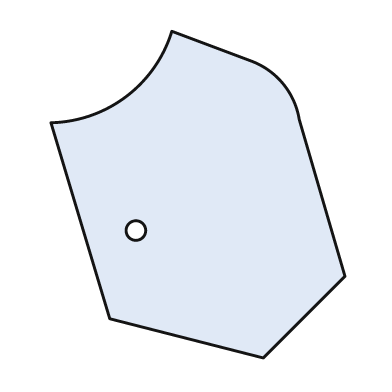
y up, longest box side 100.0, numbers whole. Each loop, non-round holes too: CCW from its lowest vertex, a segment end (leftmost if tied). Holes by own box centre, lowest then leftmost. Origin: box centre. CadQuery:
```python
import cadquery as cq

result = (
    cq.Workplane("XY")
    .moveTo(20.0, -50.0)
    .lineTo(45.0, -25.0)
    .lineTo(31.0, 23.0)
    .threePointArc((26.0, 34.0), (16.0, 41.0))
    .lineTo(-8.0, 50.0)
    .threePointArc((-22.0, 30.0), (-45.0, 22.0))
    .lineTo(-27.0, -38.0)
    .close()
    .moveTo(-19.0, -11.0)
    .circle(3.0)
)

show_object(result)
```